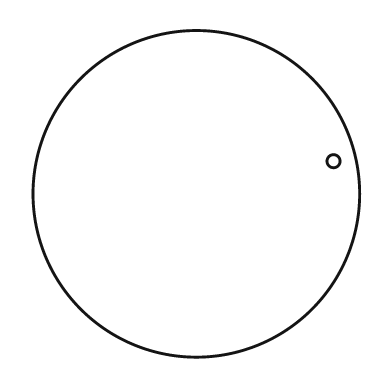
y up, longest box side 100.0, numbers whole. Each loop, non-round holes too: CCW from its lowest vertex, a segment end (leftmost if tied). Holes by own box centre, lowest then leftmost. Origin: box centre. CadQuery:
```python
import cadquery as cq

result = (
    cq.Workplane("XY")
    .moveTo(0.0, 0.0)
    .circle(50.0)
    .moveTo(42.0, 10.0)
    .circle(2.0)
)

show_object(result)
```